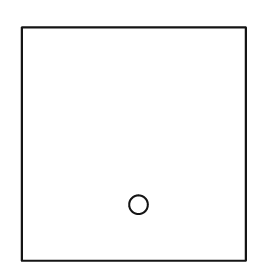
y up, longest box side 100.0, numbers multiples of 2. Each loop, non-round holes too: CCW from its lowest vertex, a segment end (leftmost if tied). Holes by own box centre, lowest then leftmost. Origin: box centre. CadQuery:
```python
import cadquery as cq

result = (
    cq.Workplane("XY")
    .moveTo(-48.0, -50.0)
    .lineTo(48.0, -50.0)
    .lineTo(48.0, 50.0)
    .lineTo(-48.0, 50.0)
    .close()
    .moveTo(2.0, -26.0)
    .circle(4.0)
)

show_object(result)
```